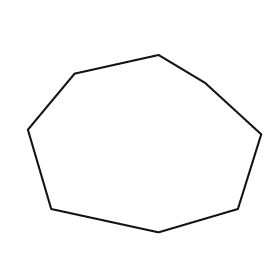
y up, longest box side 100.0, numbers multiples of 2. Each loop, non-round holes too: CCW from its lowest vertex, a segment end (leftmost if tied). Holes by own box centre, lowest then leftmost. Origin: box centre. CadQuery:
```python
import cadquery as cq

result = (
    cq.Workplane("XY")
    .moveTo(6.0, -38.0)
    .lineTo(40.0, -28.0)
    .lineTo(50.0, 4.0)
    .lineTo(26.0, 26.0)
    .lineTo(6.0, 38.0)
    .lineTo(-30.0, 30.0)
    .lineTo(-50.0, 6.0)
    .lineTo(-40.0, -28.0)
    .close()
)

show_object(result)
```